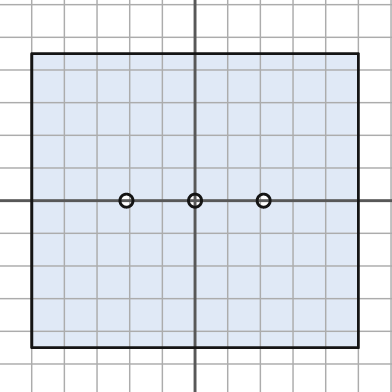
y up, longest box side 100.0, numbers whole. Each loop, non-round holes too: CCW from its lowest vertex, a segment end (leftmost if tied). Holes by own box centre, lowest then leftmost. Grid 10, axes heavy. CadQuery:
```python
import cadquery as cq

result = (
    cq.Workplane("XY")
    .moveTo(-50.0, -45.0)
    .lineTo(50.0, -45.0)
    .lineTo(50.0, 45.0)
    .lineTo(-50.0, 45.0)
    .close()
    .moveTo(-21.0, 0.0)
    .circle(2.0)
    .moveTo(0.0, 0.0)
    .circle(2.0)
    .moveTo(21.0, 0.0)
    .circle(2.0)
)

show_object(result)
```